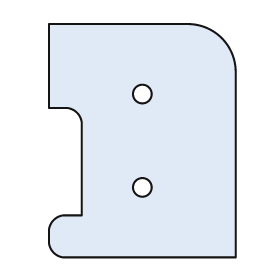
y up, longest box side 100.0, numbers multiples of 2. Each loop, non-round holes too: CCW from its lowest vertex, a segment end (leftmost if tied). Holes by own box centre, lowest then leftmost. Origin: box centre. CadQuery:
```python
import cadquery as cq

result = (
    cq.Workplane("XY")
    .moveTo(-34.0, -50.0)
    .lineTo(40.0, -50.0)
    .lineTo(40.0, 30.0)
    .threePointArc((34.0, 44.0), (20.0, 50.0))
    .lineTo(-40.0, 50.0)
    .lineTo(-40.0, 14.0)
    .lineTo(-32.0, 14.0)
    .threePointArc((-28.0, 12.0), (-26.0, 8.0))
    .lineTo(-26.0, -32.0)
    .lineTo(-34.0, -32.0)
    .threePointArc((-38.0, -34.0), (-40.0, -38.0))
    .lineTo(-40.0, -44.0)
    .threePointArc((-38.0, -48.0), (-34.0, -50.0))
    .close()
    .moveTo(0.0, -20.0)
    .circle(4.0)
    .moveTo(0.0, 20.0)
    .circle(4.0)
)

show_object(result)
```